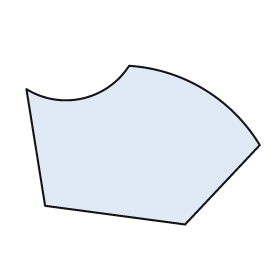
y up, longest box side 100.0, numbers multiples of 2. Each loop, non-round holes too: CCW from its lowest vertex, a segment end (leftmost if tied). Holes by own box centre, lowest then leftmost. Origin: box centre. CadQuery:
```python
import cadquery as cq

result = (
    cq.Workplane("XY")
    .moveTo(18.0, -34.0)
    .lineTo(50.0, 0.0)
    .threePointArc((26.0, 24.0), (-6.0, 34.0))
    .threePointArc((-26.0, 20.0), (-50.0, 24.0))
    .lineTo(-42.0, -26.0)
    .close()
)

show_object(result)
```